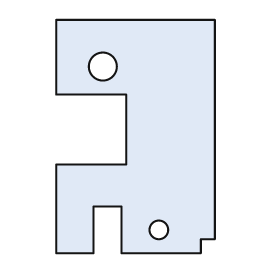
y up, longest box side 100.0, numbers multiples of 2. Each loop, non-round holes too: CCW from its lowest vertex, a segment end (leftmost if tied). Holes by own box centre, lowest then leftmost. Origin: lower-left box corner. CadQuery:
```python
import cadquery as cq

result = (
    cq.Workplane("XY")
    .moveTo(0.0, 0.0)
    .lineTo(16.0, 0.0)
    .lineTo(16.0, 20.0)
    .lineTo(28.0, 20.0)
    .lineTo(28.0, 0.0)
    .lineTo(62.0, 0.0)
    .lineTo(62.0, 6.0)
    .lineTo(68.0, 6.0)
    .lineTo(68.0, 100.0)
    .lineTo(0.0, 100.0)
    .lineTo(0.0, 68.0)
    .lineTo(30.0, 68.0)
    .lineTo(30.0, 38.0)
    .lineTo(0.0, 38.0)
    .close()
    .moveTo(44.0, 10.0)
    .circle(4.0)
    .moveTo(20.0, 80.0)
    .circle(6.0)
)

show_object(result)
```